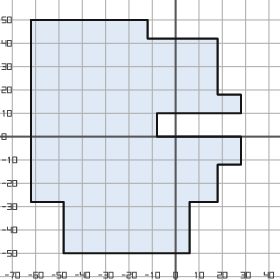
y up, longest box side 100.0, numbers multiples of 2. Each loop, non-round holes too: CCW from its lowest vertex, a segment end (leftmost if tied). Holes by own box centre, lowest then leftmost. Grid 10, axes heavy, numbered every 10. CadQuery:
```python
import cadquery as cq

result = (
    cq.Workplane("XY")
    .moveTo(-48.0, -50.0)
    .lineTo(6.0, -50.0)
    .lineTo(6.0, -28.0)
    .lineTo(18.0, -28.0)
    .lineTo(18.0, -12.0)
    .lineTo(28.0, -12.0)
    .lineTo(28.0, 0.0)
    .lineTo(-8.0, 0.0)
    .lineTo(-8.0, 10.0)
    .lineTo(28.0, 10.0)
    .lineTo(28.0, 18.0)
    .lineTo(18.0, 18.0)
    .lineTo(18.0, 42.0)
    .lineTo(-12.0, 42.0)
    .lineTo(-12.0, 50.0)
    .lineTo(-62.0, 50.0)
    .lineTo(-62.0, -28.0)
    .lineTo(-48.0, -28.0)
    .close()
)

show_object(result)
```